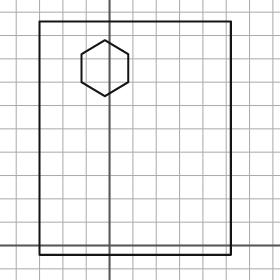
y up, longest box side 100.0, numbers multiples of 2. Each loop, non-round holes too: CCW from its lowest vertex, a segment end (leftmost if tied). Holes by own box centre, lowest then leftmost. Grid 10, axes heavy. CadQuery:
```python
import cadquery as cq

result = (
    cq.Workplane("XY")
    .moveTo(-30.0, -4.0)
    .lineTo(52.0, -4.0)
    .lineTo(52.0, 96.0)
    .lineTo(-30.0, 96.0)
    .close()
    .moveTo(-2.0, 64.0)
    .lineTo(8.0, 70.0)
    .lineTo(8.0, 82.0)
    .lineTo(-2.0, 88.0)
    .lineTo(-12.0, 82.0)
    .lineTo(-12.0, 70.0)
    .close()
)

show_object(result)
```